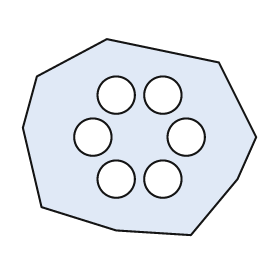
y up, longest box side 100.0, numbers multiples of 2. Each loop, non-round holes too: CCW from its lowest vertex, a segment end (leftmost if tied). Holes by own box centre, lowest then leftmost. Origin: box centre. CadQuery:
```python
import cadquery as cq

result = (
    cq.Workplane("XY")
    .moveTo(22.0, -42.0)
    .lineTo(42.0, -18.0)
    .lineTo(50.0, 0.0)
    .lineTo(34.0, 32.0)
    .lineTo(-14.0, 42.0)
    .lineTo(-44.0, 26.0)
    .lineTo(-50.0, 4.0)
    .lineTo(-42.0, -30.0)
    .lineTo(-10.0, -40.0)
    .close()
    .moveTo(-10.0, -18.0)
    .circle(8.0)
    .moveTo(10.0, -18.0)
    .circle(8.0)
    .moveTo(-20.0, 0.0)
    .circle(8.0)
    .moveTo(20.0, 0.0)
    .circle(8.0)
    .moveTo(-10.0, 18.0)
    .circle(8.0)
    .moveTo(10.0, 18.0)
    .circle(8.0)
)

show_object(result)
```